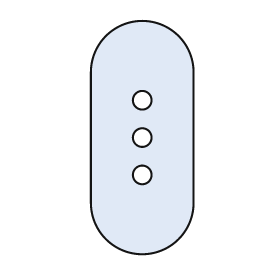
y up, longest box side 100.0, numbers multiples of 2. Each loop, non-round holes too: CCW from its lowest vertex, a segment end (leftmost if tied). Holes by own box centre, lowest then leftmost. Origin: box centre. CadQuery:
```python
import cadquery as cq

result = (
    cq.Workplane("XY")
    .moveTo(-22.0, -28.0)
    .threePointArc((0.0, -50.0), (22.0, -28.0))
    .lineTo(22.0, 28.0)
    .threePointArc((0.0, 50.0), (-22.0, 28.0))
    .close()
    .moveTo(0.0, -16.0)
    .circle(4.0)
    .moveTo(0.0, 0.0)
    .circle(4.0)
    .moveTo(0.0, 16.0)
    .circle(4.0)
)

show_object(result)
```